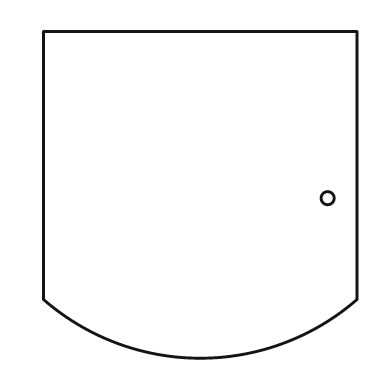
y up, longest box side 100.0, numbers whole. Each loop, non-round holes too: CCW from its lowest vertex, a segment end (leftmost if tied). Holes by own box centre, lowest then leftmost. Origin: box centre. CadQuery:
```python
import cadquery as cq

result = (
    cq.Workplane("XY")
    .moveTo(-48.0, -32.0)
    .threePointArc((0.0, -50.0), (48.0, -32.0))
    .lineTo(48.0, 50.0)
    .lineTo(-48.0, 50.0)
    .close()
    .moveTo(39.0, -1.0)
    .circle(2.0)
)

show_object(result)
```